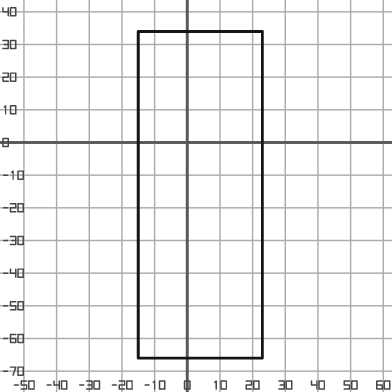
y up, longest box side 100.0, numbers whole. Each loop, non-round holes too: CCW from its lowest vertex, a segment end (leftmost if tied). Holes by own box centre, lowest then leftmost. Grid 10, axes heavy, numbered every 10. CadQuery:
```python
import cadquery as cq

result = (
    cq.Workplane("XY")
    .moveTo(-15.0, -66.0)
    .lineTo(23.0, -66.0)
    .lineTo(23.0, 34.0)
    .lineTo(-15.0, 34.0)
    .close()
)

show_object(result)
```